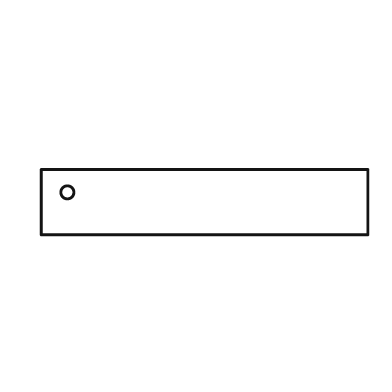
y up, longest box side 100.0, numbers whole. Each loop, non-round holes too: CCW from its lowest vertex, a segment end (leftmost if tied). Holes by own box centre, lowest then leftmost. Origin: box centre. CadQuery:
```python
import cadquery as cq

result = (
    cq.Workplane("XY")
    .moveTo(-50.0, -10.0)
    .lineTo(50.0, -10.0)
    .lineTo(50.0, 10.0)
    .lineTo(-50.0, 10.0)
    .close()
    .moveTo(-42.0, 3.0)
    .circle(2.0)
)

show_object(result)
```